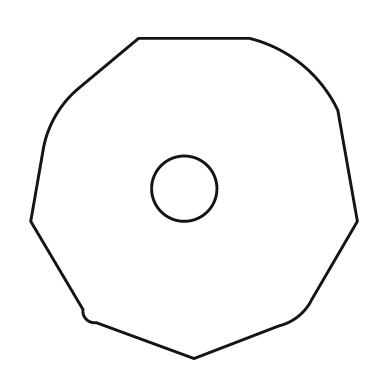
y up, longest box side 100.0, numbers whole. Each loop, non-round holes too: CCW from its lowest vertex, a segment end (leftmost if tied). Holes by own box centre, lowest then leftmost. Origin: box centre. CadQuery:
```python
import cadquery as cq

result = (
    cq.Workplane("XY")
    .moveTo(0.0, -49.0)
    .lineTo(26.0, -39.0)
    .threePointArc((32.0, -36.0), (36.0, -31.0))
    .lineTo(50.0, -7.0)
    .lineTo(44.0, 27.0)
    .threePointArc((33.0, 41.0), (17.0, 49.0))
    .lineTo(-17.0, 49.0)
    .lineTo(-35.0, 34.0)
    .threePointArc((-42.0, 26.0), (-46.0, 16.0))
    .lineTo(-50.0, -7.0)
    .lineTo(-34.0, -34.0)
    .threePointArc((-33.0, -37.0), (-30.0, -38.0))
    .close()
    .moveTo(-3.0, 3.0)
    .circle(10.0)
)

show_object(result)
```